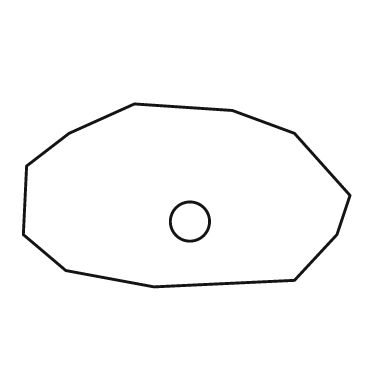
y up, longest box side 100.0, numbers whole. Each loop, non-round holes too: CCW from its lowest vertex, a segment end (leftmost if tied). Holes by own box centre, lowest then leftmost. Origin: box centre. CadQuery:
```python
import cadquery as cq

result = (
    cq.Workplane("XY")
    .moveTo(-10.0, -28.0)
    .lineTo(33.0, -26.0)
    .lineTo(46.0, -12.0)
    .lineTo(50.0, 0.0)
    .lineTo(33.0, 19.0)
    .lineTo(14.0, 26.0)
    .lineTo(-16.0, 28.0)
    .lineTo(-36.0, 19.0)
    .lineTo(-49.0, 9.0)
    .lineTo(-50.0, -12.0)
    .lineTo(-37.0, -23.0)
    .close()
    .moveTo(1.0, -8.0)
    .circle(6.0)
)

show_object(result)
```